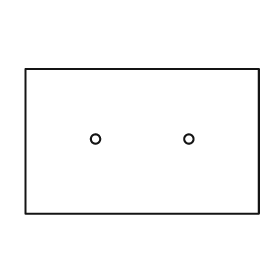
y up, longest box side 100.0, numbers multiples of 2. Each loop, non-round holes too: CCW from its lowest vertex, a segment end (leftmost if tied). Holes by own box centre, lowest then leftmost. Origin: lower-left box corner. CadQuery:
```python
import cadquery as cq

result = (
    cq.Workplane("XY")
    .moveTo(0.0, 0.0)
    .lineTo(100.0, 0.0)
    .lineTo(100.0, 62.0)
    .lineTo(0.0, 62.0)
    .close()
    .moveTo(30.0, 32.0)
    .circle(2.0)
    .moveTo(70.0, 32.0)
    .circle(2.0)
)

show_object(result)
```